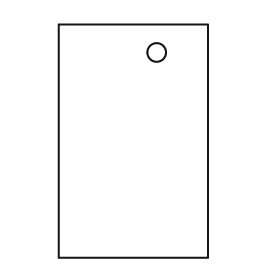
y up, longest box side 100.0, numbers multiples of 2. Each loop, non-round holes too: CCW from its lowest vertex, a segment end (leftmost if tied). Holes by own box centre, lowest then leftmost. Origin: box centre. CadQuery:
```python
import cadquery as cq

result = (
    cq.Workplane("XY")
    .moveTo(-32.0, -50.0)
    .lineTo(32.0, -50.0)
    .lineTo(32.0, 50.0)
    .lineTo(-32.0, 50.0)
    .close()
    .moveTo(10.0, 38.0)
    .circle(4.0)
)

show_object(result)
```